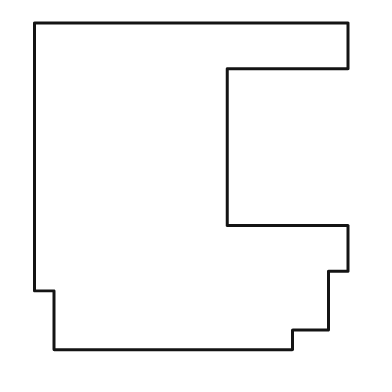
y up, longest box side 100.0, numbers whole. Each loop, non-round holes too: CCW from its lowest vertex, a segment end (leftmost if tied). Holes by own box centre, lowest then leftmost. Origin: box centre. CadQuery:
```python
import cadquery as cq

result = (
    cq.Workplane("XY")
    .moveTo(-42.0, -50.0)
    .lineTo(31.0, -50.0)
    .lineTo(31.0, -44.0)
    .lineTo(42.0, -44.0)
    .lineTo(42.0, -26.0)
    .lineTo(48.0, -26.0)
    .lineTo(48.0, -12.0)
    .lineTo(11.0, -12.0)
    .lineTo(11.0, 36.0)
    .lineTo(48.0, 36.0)
    .lineTo(48.0, 50.0)
    .lineTo(-48.0, 50.0)
    .lineTo(-48.0, -32.0)
    .lineTo(-42.0, -32.0)
    .close()
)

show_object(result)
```